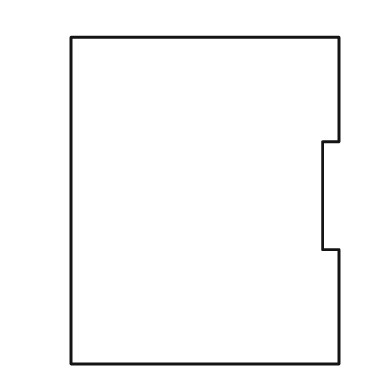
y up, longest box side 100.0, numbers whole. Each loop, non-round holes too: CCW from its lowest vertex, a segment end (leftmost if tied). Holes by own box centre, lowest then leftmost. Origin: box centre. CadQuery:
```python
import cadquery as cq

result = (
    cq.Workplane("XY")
    .moveTo(-41.0, -50.0)
    .lineTo(41.0, -50.0)
    .lineTo(41.0, -15.0)
    .lineTo(36.0, -15.0)
    .lineTo(36.0, 18.0)
    .lineTo(41.0, 18.0)
    .lineTo(41.0, 50.0)
    .lineTo(-41.0, 50.0)
    .close()
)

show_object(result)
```